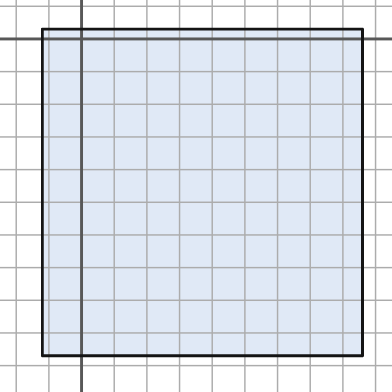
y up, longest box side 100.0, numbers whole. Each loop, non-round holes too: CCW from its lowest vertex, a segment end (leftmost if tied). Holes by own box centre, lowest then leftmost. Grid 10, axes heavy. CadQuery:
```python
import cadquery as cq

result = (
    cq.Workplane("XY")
    .moveTo(-12.0, -97.0)
    .lineTo(86.0, -97.0)
    .lineTo(86.0, 3.0)
    .lineTo(-12.0, 3.0)
    .close()
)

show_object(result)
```